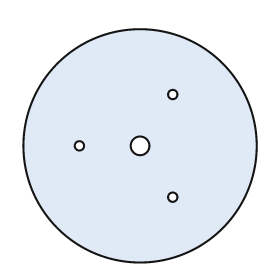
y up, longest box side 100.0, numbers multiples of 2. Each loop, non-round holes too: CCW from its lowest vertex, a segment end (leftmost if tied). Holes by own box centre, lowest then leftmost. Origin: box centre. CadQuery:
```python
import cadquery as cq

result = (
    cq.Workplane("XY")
    .moveTo(0.0, 0.0)
    .circle(50.0)
    .moveTo(14.0, -22.0)
    .circle(2.0)
    .moveTo(-26.0, 0.0)
    .circle(2.0)
    .moveTo(0.0, 0.0)
    .circle(4.0)
    .moveTo(14.0, 22.0)
    .circle(2.0)
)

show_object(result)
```